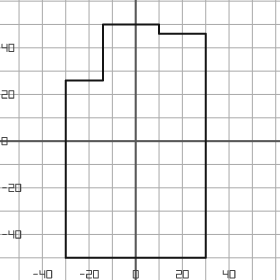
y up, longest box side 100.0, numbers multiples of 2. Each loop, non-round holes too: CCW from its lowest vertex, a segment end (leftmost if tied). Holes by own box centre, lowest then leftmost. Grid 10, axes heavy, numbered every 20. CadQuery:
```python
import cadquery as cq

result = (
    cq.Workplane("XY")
    .moveTo(-30.0, -50.0)
    .lineTo(30.0, -50.0)
    .lineTo(30.0, 46.0)
    .lineTo(10.0, 46.0)
    .lineTo(10.0, 50.0)
    .lineTo(-14.0, 50.0)
    .lineTo(-14.0, 26.0)
    .lineTo(-30.0, 26.0)
    .close()
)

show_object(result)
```